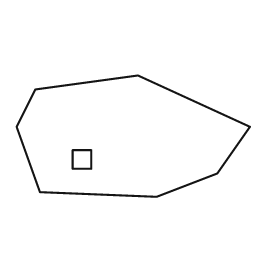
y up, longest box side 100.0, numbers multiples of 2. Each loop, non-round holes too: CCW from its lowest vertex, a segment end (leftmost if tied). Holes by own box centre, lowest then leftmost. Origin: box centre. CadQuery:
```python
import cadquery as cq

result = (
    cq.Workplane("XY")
    .moveTo(10.0, -26.0)
    .lineTo(36.0, -16.0)
    .lineTo(50.0, 4.0)
    .lineTo(2.0, 26.0)
    .lineTo(-42.0, 20.0)
    .lineTo(-50.0, 4.0)
    .lineTo(-40.0, -24.0)
    .close()
    .moveTo(-26.0, -14.0)
    .lineTo(-18.0, -14.0)
    .lineTo(-18.0, -6.0)
    .lineTo(-26.0, -6.0)
    .close()
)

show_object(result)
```